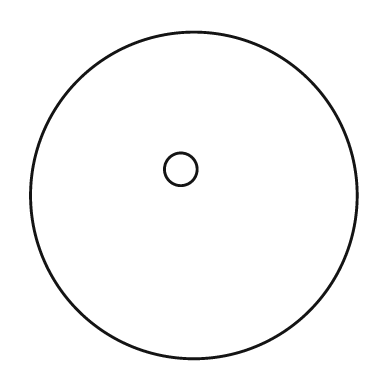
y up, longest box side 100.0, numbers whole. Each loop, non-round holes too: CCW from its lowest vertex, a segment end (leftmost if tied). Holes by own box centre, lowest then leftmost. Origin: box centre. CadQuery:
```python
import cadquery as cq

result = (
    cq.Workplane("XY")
    .moveTo(0.0, 0.0)
    .circle(50.0)
    .moveTo(-4.0, 8.0)
    .circle(5.0)
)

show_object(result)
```